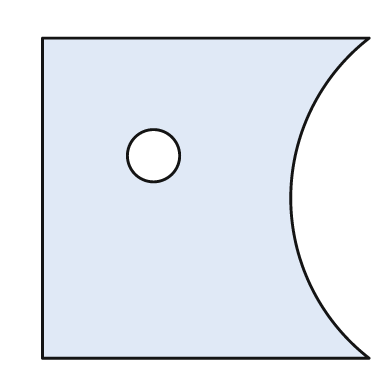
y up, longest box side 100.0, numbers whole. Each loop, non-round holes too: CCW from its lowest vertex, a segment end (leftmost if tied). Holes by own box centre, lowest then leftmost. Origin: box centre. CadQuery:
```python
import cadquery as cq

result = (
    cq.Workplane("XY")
    .moveTo(-50.0, -49.0)
    .lineTo(50.0, -49.0)
    .threePointArc((26.0, 0.0), (50.0, 49.0))
    .lineTo(-50.0, 49.0)
    .close()
    .moveTo(-16.0, 13.0)
    .circle(8.0)
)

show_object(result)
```